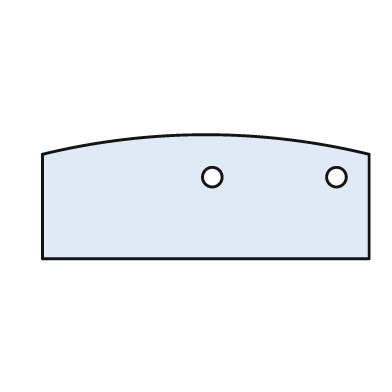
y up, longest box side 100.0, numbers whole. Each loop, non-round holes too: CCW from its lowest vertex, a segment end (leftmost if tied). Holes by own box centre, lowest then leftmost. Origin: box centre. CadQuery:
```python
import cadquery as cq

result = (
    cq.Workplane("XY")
    .moveTo(-50.0, -19.0)
    .lineTo(50.0, -19.0)
    .lineTo(50.0, 13.0)
    .threePointArc((0.0, 19.0), (-50.0, 13.0))
    .close()
    .moveTo(2.0, 6.0)
    .circle(3.0)
    .moveTo(40.0, 6.0)
    .circle(3.0)
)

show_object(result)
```